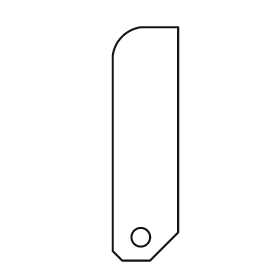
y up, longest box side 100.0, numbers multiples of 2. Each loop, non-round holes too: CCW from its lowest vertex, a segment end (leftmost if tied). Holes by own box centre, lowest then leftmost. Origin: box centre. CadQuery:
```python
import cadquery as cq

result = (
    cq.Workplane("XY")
    .moveTo(-10.0, -50.0)
    .lineTo(2.0, -50.0)
    .lineTo(14.0, -38.0)
    .lineTo(14.0, 50.0)
    .lineTo(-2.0, 50.0)
    .threePointArc((-10.0, 46.0), (-14.0, 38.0))
    .lineTo(-14.0, -46.0)
    .close()
    .moveTo(-2.0, -40.0)
    .circle(4.0)
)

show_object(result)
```